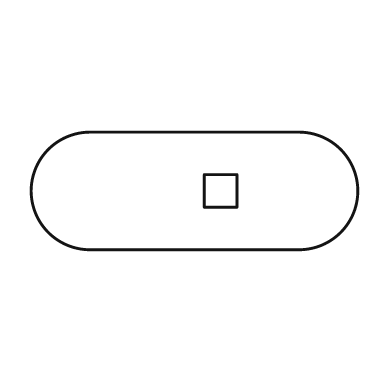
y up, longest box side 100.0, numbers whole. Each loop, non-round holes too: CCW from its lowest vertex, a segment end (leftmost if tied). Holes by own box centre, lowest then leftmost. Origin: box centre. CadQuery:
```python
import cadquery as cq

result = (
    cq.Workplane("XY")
    .moveTo(-32.0, -18.0)
    .lineTo(32.0, -18.0)
    .threePointArc((50.0, 0.0), (32.0, 18.0))
    .lineTo(-32.0, 18.0)
    .threePointArc((-50.0, 0.0), (-32.0, -18.0))
    .close()
    .moveTo(3.0, -5.0)
    .lineTo(13.0, -5.0)
    .lineTo(13.0, 5.0)
    .lineTo(3.0, 5.0)
    .close()
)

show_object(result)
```